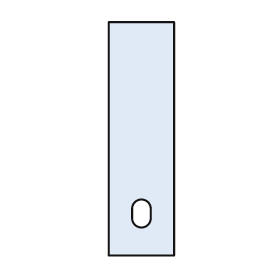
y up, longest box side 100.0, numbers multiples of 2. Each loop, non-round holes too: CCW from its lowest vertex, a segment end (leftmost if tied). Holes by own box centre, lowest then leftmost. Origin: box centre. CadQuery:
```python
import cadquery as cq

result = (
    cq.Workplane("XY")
    .moveTo(-14.0, -50.0)
    .lineTo(14.0, -50.0)
    .lineTo(14.0, 50.0)
    .lineTo(-14.0, 50.0)
    .close()
    .moveTo(-4.0, -34.0)
    .threePointArc((0.0, -38.0), (4.0, -34.0))
    .lineTo(4.0, -30.0)
    .threePointArc((0.0, -26.0), (-4.0, -30.0))
    .close()
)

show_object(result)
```